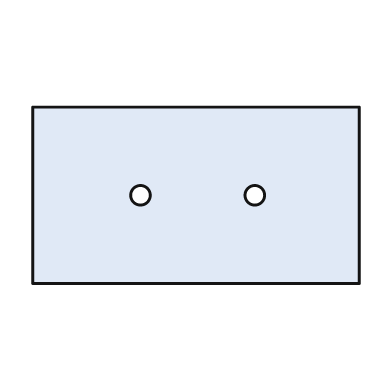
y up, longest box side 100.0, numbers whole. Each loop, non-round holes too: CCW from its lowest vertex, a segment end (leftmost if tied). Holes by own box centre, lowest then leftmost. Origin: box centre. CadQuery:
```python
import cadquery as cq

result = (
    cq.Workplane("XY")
    .moveTo(-50.0, -27.0)
    .lineTo(50.0, -27.0)
    .lineTo(50.0, 27.0)
    .lineTo(-50.0, 27.0)
    .close()
    .moveTo(-17.0, 0.0)
    .circle(3.0)
    .moveTo(18.0, 0.0)
    .circle(3.0)
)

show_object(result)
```